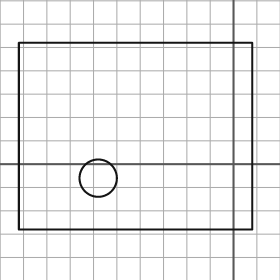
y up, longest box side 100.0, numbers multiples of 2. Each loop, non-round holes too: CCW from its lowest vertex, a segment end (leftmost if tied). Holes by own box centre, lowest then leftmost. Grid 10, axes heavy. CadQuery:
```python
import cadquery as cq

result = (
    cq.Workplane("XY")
    .moveTo(-92.0, -28.0)
    .lineTo(8.0, -28.0)
    .lineTo(8.0, 52.0)
    .lineTo(-92.0, 52.0)
    .close()
    .moveTo(-58.0, -6.0)
    .circle(8.0)
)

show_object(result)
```